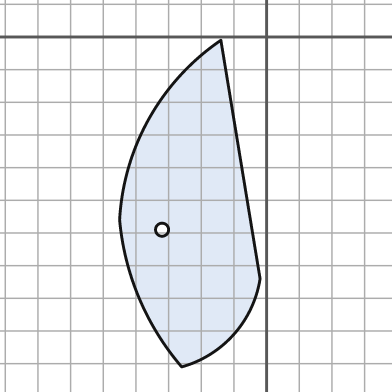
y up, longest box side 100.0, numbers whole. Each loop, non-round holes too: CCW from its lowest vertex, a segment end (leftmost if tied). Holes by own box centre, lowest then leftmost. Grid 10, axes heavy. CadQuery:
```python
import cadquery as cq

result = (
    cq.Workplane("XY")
    .moveTo(-26.0, -101.0)
    .threePointArc((-10.0, -91.0), (-2.0, -74.0))
    .lineTo(-14.0, -1.0)
    .threePointArc((-36.0, -25.0), (-45.0, -56.0))
    .threePointArc((-39.0, -80.0), (-26.0, -101.0))
    .close()
    .moveTo(-32.0, -59.0)
    .circle(2.0)
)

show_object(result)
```